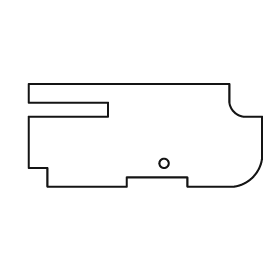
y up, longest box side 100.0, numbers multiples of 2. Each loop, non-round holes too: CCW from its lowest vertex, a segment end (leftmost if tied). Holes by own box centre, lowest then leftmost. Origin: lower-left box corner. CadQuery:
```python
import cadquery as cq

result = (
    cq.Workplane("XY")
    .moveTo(8.0, 0.0)
    .lineTo(42.0, 0.0)
    .lineTo(42.0, 4.0)
    .lineTo(68.0, 4.0)
    .lineTo(68.0, 0.0)
    .lineTo(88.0, 0.0)
    .threePointArc((96.0, 4.0), (100.0, 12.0))
    .lineTo(100.0, 30.0)
    .lineTo(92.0, 30.0)
    .threePointArc((88.0, 32.0), (86.0, 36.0))
    .lineTo(86.0, 44.0)
    .lineTo(0.0, 44.0)
    .lineTo(0.0, 36.0)
    .lineTo(34.0, 36.0)
    .lineTo(34.0, 30.0)
    .lineTo(0.0, 30.0)
    .lineTo(0.0, 8.0)
    .lineTo(8.0, 8.0)
    .close()
    .moveTo(58.0, 10.0)
    .circle(2.0)
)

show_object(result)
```